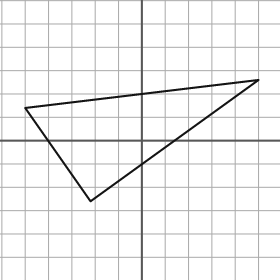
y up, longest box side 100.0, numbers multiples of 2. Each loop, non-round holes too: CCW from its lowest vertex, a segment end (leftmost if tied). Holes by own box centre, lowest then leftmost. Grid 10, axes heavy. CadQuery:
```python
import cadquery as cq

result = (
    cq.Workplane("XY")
    .moveTo(-22.0, -26.0)
    .lineTo(50.0, 26.0)
    .lineTo(-50.0, 14.0)
    .close()
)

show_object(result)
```